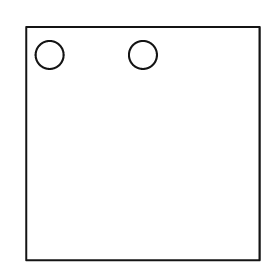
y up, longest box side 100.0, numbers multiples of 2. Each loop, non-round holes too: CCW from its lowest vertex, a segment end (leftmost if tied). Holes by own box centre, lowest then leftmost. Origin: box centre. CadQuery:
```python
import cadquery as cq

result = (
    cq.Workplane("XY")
    .moveTo(-50.0, -50.0)
    .lineTo(50.0, -50.0)
    .lineTo(50.0, 50.0)
    .lineTo(-50.0, 50.0)
    .close()
    .moveTo(-40.0, 38.0)
    .circle(6.0)
    .moveTo(0.0, 38.0)
    .circle(6.0)
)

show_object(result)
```